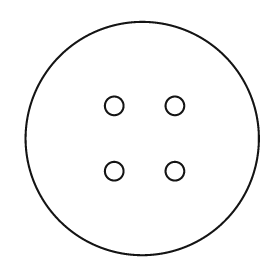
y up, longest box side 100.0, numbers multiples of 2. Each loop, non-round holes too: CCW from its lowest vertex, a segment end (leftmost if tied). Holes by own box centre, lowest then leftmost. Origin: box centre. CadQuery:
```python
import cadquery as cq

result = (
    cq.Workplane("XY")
    .moveTo(0.0, 0.0)
    .circle(50.0)
    .moveTo(-12.0, -14.0)
    .circle(4.0)
    .moveTo(14.0, -14.0)
    .circle(4.0)
    .moveTo(-12.0, 14.0)
    .circle(4.0)
    .moveTo(14.0, 14.0)
    .circle(4.0)
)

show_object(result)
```